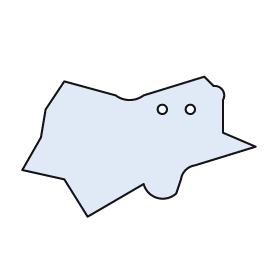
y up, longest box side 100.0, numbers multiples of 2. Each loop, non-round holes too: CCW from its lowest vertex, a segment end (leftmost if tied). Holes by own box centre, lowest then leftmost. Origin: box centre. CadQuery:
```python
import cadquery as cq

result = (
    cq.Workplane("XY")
    .moveTo(-22.0, -30.0)
    .lineTo(2.0, -16.0)
    .threePointArc((8.0, -22.0), (16.0, -20.0))
    .lineTo(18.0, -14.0)
    .threePointArc((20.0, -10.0), (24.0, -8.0))
    .lineTo(50.0, 0.0)
    .lineTo(36.0, 6.0)
    .lineTo(36.0, 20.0)
    .threePointArc((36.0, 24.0), (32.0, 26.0))
    .lineTo(28.0, 30.0)
    .lineTo(2.0, 22.0)
    .threePointArc((-4.0, 20.0), (-10.0, 22.0))
    .lineTo(-32.0, 28.0)
    .lineTo(-40.0, 16.0)
    .lineTo(-42.0, 4.0)
    .lineTo(-50.0, -10.0)
    .lineTo(-32.0, -14.0)
    .close()
    .moveTo(10.0, 16.0)
    .circle(2.0)
    .moveTo(22.0, 16.0)
    .circle(2.0)
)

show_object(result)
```